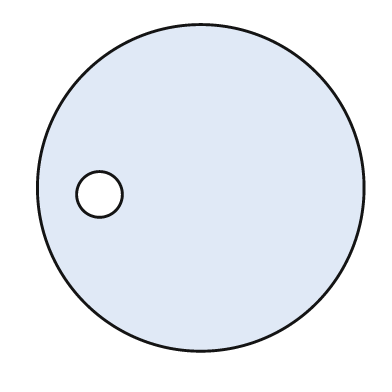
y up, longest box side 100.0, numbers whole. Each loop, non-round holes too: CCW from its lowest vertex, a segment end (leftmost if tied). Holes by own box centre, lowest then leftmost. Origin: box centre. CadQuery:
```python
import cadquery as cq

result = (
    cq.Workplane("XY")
    .moveTo(0.0, 0.0)
    .circle(50.0)
    .moveTo(-31.0, -2.0)
    .circle(7.0)
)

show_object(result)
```